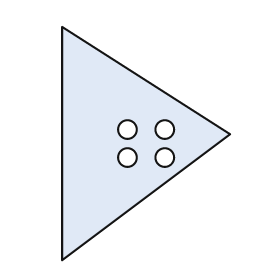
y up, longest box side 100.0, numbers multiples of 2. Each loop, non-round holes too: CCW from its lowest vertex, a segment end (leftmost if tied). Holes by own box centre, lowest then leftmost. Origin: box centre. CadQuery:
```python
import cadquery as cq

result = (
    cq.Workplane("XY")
    .moveTo(-36.0, -50.0)
    .lineTo(36.0, 4.0)
    .lineTo(-36.0, 50.0)
    .close()
    .moveTo(-8.0, -6.0)
    .circle(4.0)
    .moveTo(8.0, -6.0)
    .circle(4.0)
    .moveTo(-8.0, 6.0)
    .circle(4.0)
    .moveTo(8.0, 6.0)
    .circle(4.0)
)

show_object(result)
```